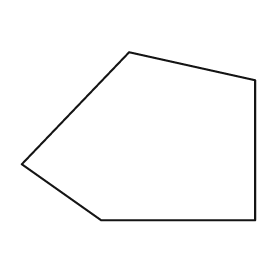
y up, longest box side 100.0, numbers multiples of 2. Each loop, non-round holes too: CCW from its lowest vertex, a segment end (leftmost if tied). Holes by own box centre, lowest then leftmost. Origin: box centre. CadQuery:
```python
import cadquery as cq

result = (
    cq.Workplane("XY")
    .moveTo(-16.0, -36.0)
    .lineTo(50.0, -36.0)
    .lineTo(50.0, 24.0)
    .lineTo(-4.0, 36.0)
    .lineTo(-50.0, -12.0)
    .close()
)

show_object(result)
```